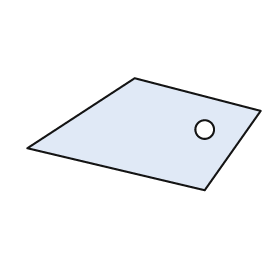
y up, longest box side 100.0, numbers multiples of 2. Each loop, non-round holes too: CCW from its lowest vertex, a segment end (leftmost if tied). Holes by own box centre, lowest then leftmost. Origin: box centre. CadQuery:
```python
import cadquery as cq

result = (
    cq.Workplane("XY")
    .moveTo(26.0, -24.0)
    .lineTo(50.0, 10.0)
    .lineTo(-4.0, 24.0)
    .lineTo(-50.0, -6.0)
    .close()
    .moveTo(26.0, 2.0)
    .circle(4.0)
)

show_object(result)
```